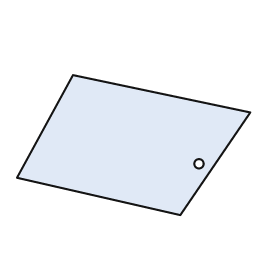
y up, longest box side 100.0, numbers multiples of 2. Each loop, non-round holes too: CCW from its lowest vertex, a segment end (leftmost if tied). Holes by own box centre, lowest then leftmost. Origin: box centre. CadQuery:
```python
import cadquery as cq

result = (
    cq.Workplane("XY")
    .moveTo(20.0, -30.0)
    .lineTo(50.0, 14.0)
    .lineTo(-26.0, 30.0)
    .lineTo(-50.0, -14.0)
    .close()
    .moveTo(28.0, -8.0)
    .circle(2.0)
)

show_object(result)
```